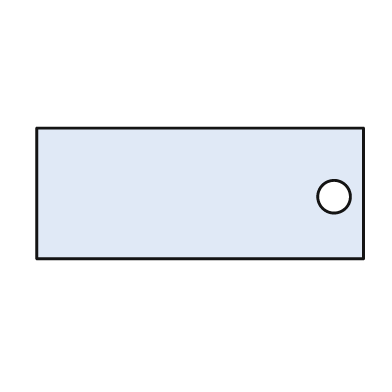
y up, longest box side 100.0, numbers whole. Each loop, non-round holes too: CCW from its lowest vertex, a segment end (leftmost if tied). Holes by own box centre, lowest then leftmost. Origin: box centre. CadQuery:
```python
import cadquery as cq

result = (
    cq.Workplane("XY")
    .moveTo(-50.0, -20.0)
    .lineTo(50.0, -20.0)
    .lineTo(50.0, 20.0)
    .lineTo(-50.0, 20.0)
    .close()
    .moveTo(41.0, -1.0)
    .circle(5.0)
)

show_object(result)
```